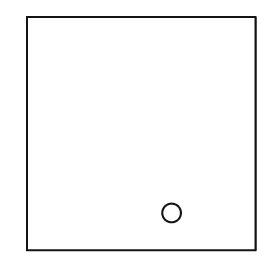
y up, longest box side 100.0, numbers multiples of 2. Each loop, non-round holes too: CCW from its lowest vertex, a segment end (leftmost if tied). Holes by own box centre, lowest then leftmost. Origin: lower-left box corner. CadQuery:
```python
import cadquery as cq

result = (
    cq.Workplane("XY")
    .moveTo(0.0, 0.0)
    .lineTo(98.0, 0.0)
    .lineTo(98.0, 100.0)
    .lineTo(0.0, 100.0)
    .close()
    .moveTo(62.0, 16.0)
    .circle(4.0)
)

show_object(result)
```